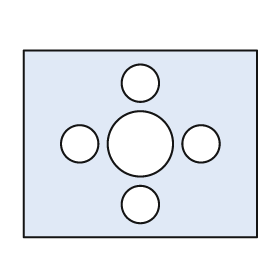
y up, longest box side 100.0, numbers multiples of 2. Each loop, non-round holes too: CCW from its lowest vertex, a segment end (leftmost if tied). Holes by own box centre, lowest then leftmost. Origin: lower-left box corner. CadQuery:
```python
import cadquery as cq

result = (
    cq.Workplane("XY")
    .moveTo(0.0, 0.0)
    .lineTo(100.0, 0.0)
    .lineTo(100.0, 80.0)
    .lineTo(0.0, 80.0)
    .close()
    .moveTo(50.0, 14.0)
    .circle(8.0)
    .moveTo(24.0, 40.0)
    .circle(8.0)
    .moveTo(50.0, 40.0)
    .circle(14.0)
    .moveTo(76.0, 40.0)
    .circle(8.0)
    .moveTo(50.0, 66.0)
    .circle(8.0)
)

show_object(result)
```